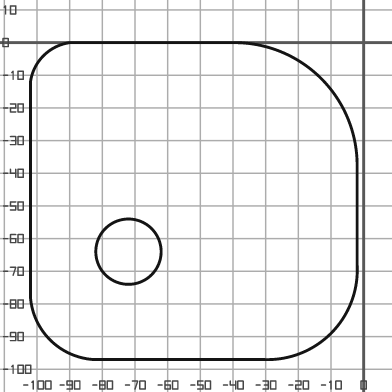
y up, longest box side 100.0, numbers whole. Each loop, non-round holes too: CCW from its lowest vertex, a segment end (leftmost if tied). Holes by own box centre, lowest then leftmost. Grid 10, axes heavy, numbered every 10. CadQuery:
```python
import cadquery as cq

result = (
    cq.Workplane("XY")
    .moveTo(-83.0, -97.0)
    .lineTo(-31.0, -97.0)
    .threePointArc((-10.0, -89.0), (-2.0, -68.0))
    .lineTo(-2.0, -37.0)
    .threePointArc((-13.0, -11.0), (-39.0, 0.0))
    .lineTo(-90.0, 0.0)
    .threePointArc((-98.0, -4.0), (-102.0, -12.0))
    .lineTo(-102.0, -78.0)
    .threePointArc((-96.0, -91.0), (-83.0, -97.0))
    .close()
    .moveTo(-72.0, -64.0)
    .circle(10.0)
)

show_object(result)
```